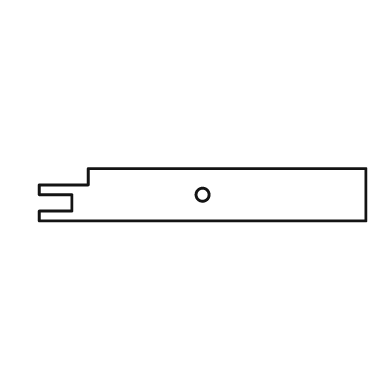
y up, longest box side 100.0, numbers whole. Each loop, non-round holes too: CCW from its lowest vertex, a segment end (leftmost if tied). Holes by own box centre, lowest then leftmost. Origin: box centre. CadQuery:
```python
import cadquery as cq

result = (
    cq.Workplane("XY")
    .moveTo(-50.0, -8.0)
    .lineTo(50.0, -8.0)
    .lineTo(50.0, 8.0)
    .lineTo(-35.0, 8.0)
    .lineTo(-35.0, 3.0)
    .lineTo(-50.0, 3.0)
    .lineTo(-50.0, 0.0)
    .lineTo(-40.0, 0.0)
    .lineTo(-40.0, -5.0)
    .lineTo(-50.0, -5.0)
    .close()
    .moveTo(0.0, 0.0)
    .circle(2.0)
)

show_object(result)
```